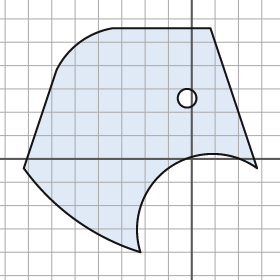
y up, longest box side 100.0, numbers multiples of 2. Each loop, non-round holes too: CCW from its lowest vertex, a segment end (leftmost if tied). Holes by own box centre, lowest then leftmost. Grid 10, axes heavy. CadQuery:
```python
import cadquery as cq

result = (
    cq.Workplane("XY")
    .moveTo(-22.0, -40.0)
    .threePointArc((-10.0, -4.0), (28.0, -4.0))
    .lineTo(8.0, 56.0)
    .lineTo(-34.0, 56.0)
    .threePointArc((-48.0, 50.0), (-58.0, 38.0))
    .lineTo(-72.0, -4.0)
    .threePointArc((-50.0, -26.0), (-22.0, -40.0))
    .close()
    .moveTo(-2.0, 26.0)
    .circle(4.0)
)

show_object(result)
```